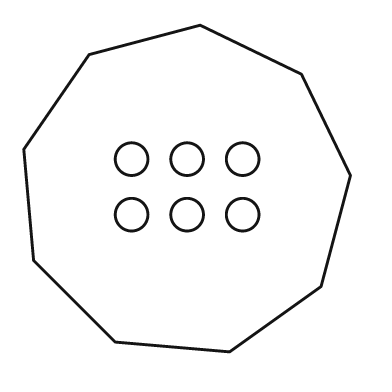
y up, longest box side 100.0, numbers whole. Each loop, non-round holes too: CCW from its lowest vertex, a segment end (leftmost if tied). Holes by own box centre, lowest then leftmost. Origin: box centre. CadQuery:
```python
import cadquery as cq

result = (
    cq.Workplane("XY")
    .moveTo(13.0, -50.0)
    .lineTo(41.0, -30.0)
    .lineTo(50.0, 4.0)
    .lineTo(35.0, 35.0)
    .lineTo(4.0, 50.0)
    .lineTo(-30.0, 41.0)
    .lineTo(-50.0, 12.0)
    .lineTo(-47.0, -22.0)
    .lineTo(-22.0, -47.0)
    .close()
    .moveTo(-17.0, -8.0)
    .circle(5.0)
    .moveTo(0.0, -8.0)
    .circle(5.0)
    .moveTo(17.0, -8.0)
    .circle(5.0)
    .moveTo(-17.0, 9.0)
    .circle(5.0)
    .moveTo(0.0, 9.0)
    .circle(5.0)
    .moveTo(17.0, 9.0)
    .circle(5.0)
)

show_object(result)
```